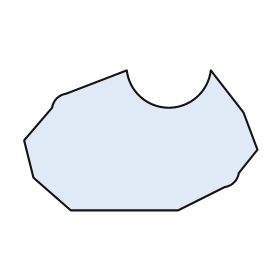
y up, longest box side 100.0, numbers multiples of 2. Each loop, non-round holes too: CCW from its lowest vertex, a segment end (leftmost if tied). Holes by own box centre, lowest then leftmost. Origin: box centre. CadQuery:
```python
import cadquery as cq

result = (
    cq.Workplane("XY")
    .moveTo(-30.0, -30.0)
    .lineTo(16.0, -30.0)
    .lineTo(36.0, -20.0)
    .threePointArc((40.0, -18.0), (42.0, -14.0))
    .lineTo(50.0, -4.0)
    .lineTo(44.0, 12.0)
    .lineTo(30.0, 30.0)
    .threePointArc((12.0, 14.0), (-6.0, 30.0))
    .lineTo(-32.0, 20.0)
    .threePointArc((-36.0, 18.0), (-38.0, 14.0))
    .lineTo(-50.0, 0.0)
    .lineTo(-46.0, -16.0)
    .close()
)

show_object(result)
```